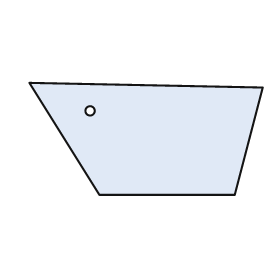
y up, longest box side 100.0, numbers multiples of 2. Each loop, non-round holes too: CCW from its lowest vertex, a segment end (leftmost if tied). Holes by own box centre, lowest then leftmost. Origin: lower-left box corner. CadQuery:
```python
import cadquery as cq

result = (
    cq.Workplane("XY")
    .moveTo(30.0, 0.0)
    .lineTo(88.0, 0.0)
    .lineTo(100.0, 46.0)
    .lineTo(0.0, 48.0)
    .close()
    .moveTo(26.0, 36.0)
    .circle(2.0)
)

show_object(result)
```